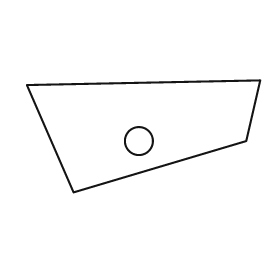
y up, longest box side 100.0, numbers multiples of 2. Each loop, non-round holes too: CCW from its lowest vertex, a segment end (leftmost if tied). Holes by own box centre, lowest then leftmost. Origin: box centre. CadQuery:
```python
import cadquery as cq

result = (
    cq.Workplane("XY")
    .moveTo(-30.0, -24.0)
    .lineTo(44.0, -2.0)
    .lineTo(50.0, 24.0)
    .lineTo(-50.0, 22.0)
    .close()
    .moveTo(-2.0, -2.0)
    .circle(6.0)
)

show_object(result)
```